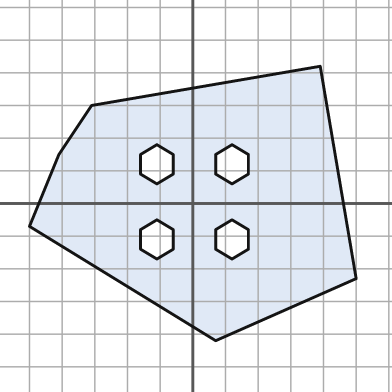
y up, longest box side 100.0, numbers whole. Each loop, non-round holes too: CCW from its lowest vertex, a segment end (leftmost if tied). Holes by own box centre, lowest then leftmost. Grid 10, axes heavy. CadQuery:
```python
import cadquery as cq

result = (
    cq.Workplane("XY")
    .moveTo(7.0, -42.0)
    .lineTo(50.0, -23.0)
    .lineTo(39.0, 42.0)
    .lineTo(-31.0, 30.0)
    .lineTo(-41.0, 15.0)
    .lineTo(-50.0, -7.0)
    .close()
    .moveTo(-11.0, -17.0)
    .lineTo(-6.0, -14.0)
    .lineTo(-6.0, -8.0)
    .lineTo(-11.0, -5.0)
    .lineTo(-16.0, -8.0)
    .lineTo(-16.0, -14.0)
    .close()
    .moveTo(12.0, -17.0)
    .lineTo(17.0, -14.0)
    .lineTo(17.0, -8.0)
    .lineTo(12.0, -5.0)
    .lineTo(7.0, -8.0)
    .lineTo(7.0, -14.0)
    .close()
    .moveTo(-11.0, 6.0)
    .lineTo(-6.0, 9.0)
    .lineTo(-6.0, 15.0)
    .lineTo(-11.0, 18.0)
    .lineTo(-16.0, 15.0)
    .lineTo(-16.0, 9.0)
    .close()
    .moveTo(12.0, 6.0)
    .lineTo(17.0, 9.0)
    .lineTo(17.0, 15.0)
    .lineTo(12.0, 18.0)
    .lineTo(7.0, 15.0)
    .lineTo(7.0, 9.0)
    .close()
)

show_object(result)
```